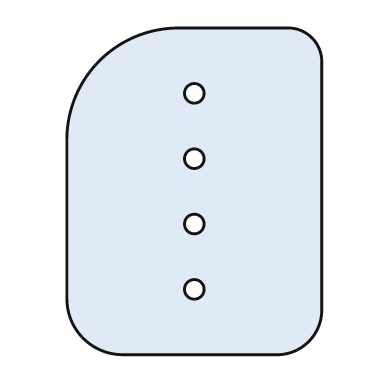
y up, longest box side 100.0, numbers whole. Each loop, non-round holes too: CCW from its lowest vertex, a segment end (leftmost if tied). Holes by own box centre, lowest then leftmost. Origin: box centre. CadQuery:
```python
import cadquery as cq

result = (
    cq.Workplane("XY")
    .moveTo(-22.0, -50.0)
    .lineTo(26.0, -50.0)
    .threePointArc((35.0, -46.0), (39.0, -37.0))
    .lineTo(39.0, 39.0)
    .threePointArc((36.0, 47.0), (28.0, 50.0))
    .lineTo(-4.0, 50.0)
    .threePointArc((-29.0, 40.0), (-39.0, 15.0))
    .lineTo(-39.0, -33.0)
    .threePointArc((-34.0, -45.0), (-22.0, -50.0))
    .close()
    .moveTo(0.0, -30.0)
    .circle(3.0)
    .moveTo(0.0, -10.0)
    .circle(3.0)
    .moveTo(0.0, 10.0)
    .circle(3.0)
    .moveTo(0.0, 30.0)
    .circle(3.0)
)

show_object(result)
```